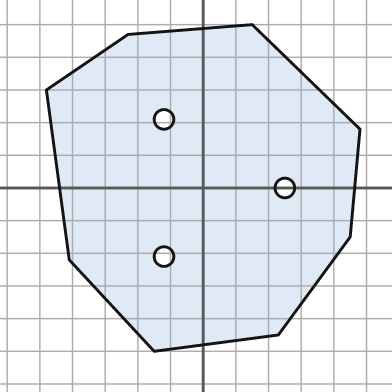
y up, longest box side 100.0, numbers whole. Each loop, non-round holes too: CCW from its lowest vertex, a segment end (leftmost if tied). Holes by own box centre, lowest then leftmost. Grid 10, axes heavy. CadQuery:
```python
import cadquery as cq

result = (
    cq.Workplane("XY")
    .moveTo(-15.0, -50.0)
    .lineTo(23.0, -45.0)
    .lineTo(45.0, -15.0)
    .lineTo(48.0, 18.0)
    .lineTo(15.0, 50.0)
    .lineTo(-23.0, 47.0)
    .lineTo(-48.0, 30.0)
    .lineTo(-41.0, -22.0)
    .close()
    .moveTo(-12.0, -21.0)
    .circle(3.0)
    .moveTo(25.0, 0.0)
    .circle(3.0)
    .moveTo(-12.0, 21.0)
    .circle(3.0)
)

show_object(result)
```